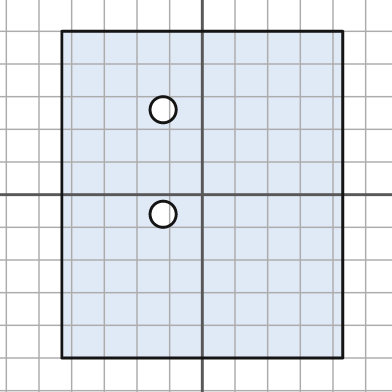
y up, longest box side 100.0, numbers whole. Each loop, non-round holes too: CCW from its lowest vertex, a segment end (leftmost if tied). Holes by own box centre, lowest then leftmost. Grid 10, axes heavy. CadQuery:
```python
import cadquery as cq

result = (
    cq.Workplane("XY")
    .moveTo(-43.0, -50.0)
    .lineTo(43.0, -50.0)
    .lineTo(43.0, 50.0)
    .lineTo(-43.0, 50.0)
    .close()
    .moveTo(-12.0, -6.0)
    .circle(4.0)
    .moveTo(-12.0, 26.0)
    .circle(4.0)
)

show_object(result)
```